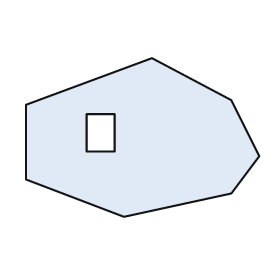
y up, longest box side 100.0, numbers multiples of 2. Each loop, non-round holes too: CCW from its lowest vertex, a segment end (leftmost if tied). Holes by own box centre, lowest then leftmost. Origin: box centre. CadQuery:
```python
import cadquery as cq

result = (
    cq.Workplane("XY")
    .moveTo(-8.0, -34.0)
    .lineTo(38.0, -24.0)
    .lineTo(50.0, -8.0)
    .lineTo(38.0, 16.0)
    .lineTo(4.0, 34.0)
    .lineTo(-50.0, 14.0)
    .lineTo(-50.0, -18.0)
    .close()
    .moveTo(-24.0, -6.0)
    .lineTo(-12.0, -6.0)
    .lineTo(-12.0, 10.0)
    .lineTo(-24.0, 10.0)
    .close()
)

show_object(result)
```